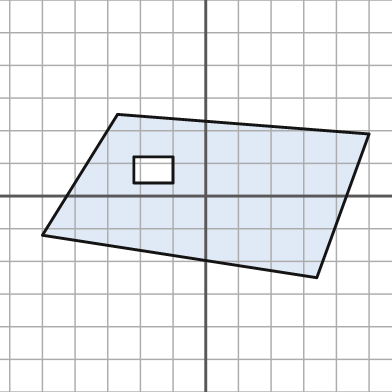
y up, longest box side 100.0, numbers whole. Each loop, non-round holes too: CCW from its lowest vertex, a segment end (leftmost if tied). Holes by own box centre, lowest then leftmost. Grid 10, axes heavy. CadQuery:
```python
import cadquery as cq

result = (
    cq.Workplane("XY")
    .moveTo(34.0, -25.0)
    .lineTo(50.0, 19.0)
    .lineTo(-27.0, 25.0)
    .lineTo(-50.0, -12.0)
    .close()
    .moveTo(-22.0, 4.0)
    .lineTo(-10.0, 4.0)
    .lineTo(-10.0, 12.0)
    .lineTo(-22.0, 12.0)
    .close()
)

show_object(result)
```